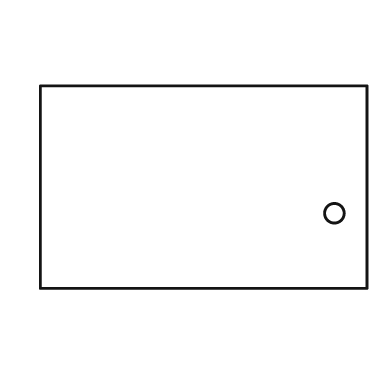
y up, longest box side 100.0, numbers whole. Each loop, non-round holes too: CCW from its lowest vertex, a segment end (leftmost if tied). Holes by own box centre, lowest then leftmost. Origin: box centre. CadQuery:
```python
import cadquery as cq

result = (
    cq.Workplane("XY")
    .moveTo(-50.0, -31.0)
    .lineTo(50.0, -31.0)
    .lineTo(50.0, 31.0)
    .lineTo(-50.0, 31.0)
    .close()
    .moveTo(40.0, -8.0)
    .circle(3.0)
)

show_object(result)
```